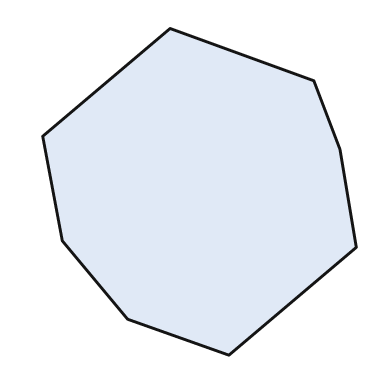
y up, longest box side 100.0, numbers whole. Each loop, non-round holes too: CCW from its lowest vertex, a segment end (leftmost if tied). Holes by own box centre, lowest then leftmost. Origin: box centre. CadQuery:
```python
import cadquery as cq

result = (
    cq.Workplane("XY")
    .moveTo(9.0, -50.0)
    .lineTo(48.0, -17.0)
    .lineTo(43.0, 13.0)
    .lineTo(35.0, 34.0)
    .lineTo(-9.0, 50.0)
    .lineTo(-48.0, 17.0)
    .lineTo(-42.0, -15.0)
    .lineTo(-22.0, -39.0)
    .close()
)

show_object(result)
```